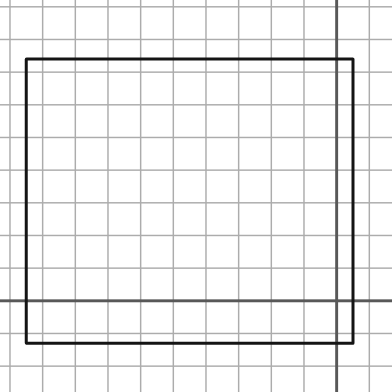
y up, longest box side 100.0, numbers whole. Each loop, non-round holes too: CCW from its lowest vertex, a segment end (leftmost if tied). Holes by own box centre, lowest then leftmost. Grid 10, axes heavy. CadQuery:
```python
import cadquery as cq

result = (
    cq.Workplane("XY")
    .moveTo(-95.0, -13.0)
    .lineTo(5.0, -13.0)
    .lineTo(5.0, 74.0)
    .lineTo(-95.0, 74.0)
    .close()
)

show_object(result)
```